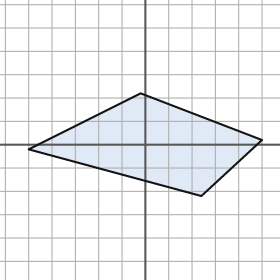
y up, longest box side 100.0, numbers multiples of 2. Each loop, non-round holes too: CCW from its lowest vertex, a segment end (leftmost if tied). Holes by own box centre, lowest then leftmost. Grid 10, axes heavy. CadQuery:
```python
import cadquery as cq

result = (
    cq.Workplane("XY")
    .moveTo(24.0, -22.0)
    .lineTo(50.0, 2.0)
    .lineTo(-2.0, 22.0)
    .lineTo(-50.0, -2.0)
    .close()
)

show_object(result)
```